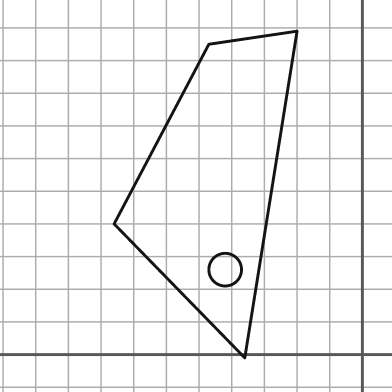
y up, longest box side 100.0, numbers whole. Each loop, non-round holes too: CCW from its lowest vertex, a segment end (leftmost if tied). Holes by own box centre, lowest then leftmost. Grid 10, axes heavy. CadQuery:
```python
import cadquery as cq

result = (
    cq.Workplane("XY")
    .moveTo(-36.0, -1.0)
    .lineTo(-20.0, 99.0)
    .lineTo(-47.0, 95.0)
    .lineTo(-76.0, 40.0)
    .close()
    .moveTo(-42.0, 26.0)
    .circle(5.0)
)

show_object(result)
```